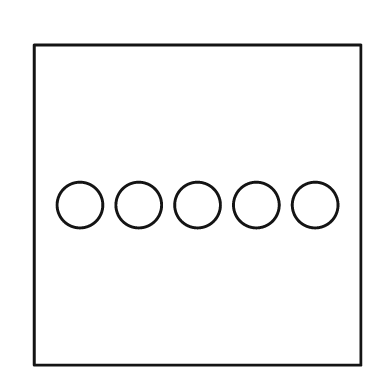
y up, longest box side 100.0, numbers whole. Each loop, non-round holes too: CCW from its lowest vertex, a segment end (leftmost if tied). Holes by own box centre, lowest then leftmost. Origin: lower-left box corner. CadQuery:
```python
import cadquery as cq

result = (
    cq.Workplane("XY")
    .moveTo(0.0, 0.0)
    .lineTo(100.0, 0.0)
    .lineTo(100.0, 98.0)
    .lineTo(0.0, 98.0)
    .close()
    .moveTo(14.0, 49.0)
    .circle(7.0)
    .moveTo(32.0, 49.0)
    .circle(7.0)
    .moveTo(50.0, 49.0)
    .circle(7.0)
    .moveTo(68.0, 49.0)
    .circle(7.0)
    .moveTo(86.0, 49.0)
    .circle(7.0)
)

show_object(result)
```